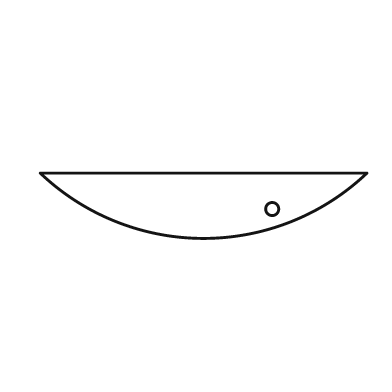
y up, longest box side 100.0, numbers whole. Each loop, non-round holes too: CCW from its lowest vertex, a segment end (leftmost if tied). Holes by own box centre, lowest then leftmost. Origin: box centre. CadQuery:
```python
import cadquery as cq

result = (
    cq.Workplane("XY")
    .moveTo(-50.0, 10.0)
    .threePointArc((0.0, -10.0), (50.0, 10.0))
    .close()
    .moveTo(21.0, -1.0)
    .circle(2.0)
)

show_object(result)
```